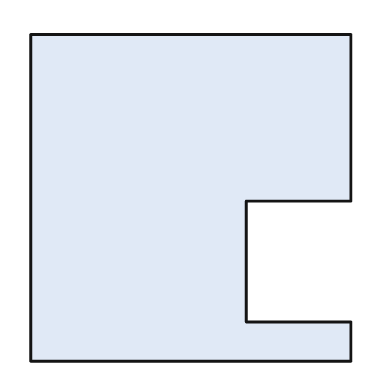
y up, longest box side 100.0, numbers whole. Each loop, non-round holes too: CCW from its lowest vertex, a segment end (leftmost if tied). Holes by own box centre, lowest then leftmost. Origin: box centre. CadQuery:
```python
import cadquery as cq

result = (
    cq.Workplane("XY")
    .moveTo(-49.0, -50.0)
    .lineTo(49.0, -50.0)
    .lineTo(49.0, -38.0)
    .lineTo(17.0, -38.0)
    .lineTo(17.0, -1.0)
    .lineTo(49.0, -1.0)
    .lineTo(49.0, 50.0)
    .lineTo(-49.0, 50.0)
    .close()
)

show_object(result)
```